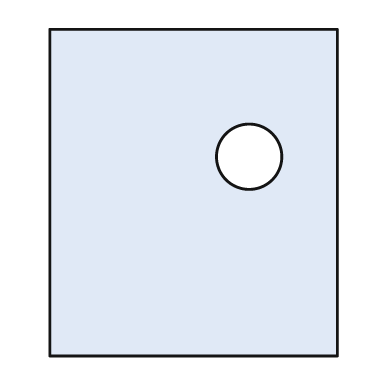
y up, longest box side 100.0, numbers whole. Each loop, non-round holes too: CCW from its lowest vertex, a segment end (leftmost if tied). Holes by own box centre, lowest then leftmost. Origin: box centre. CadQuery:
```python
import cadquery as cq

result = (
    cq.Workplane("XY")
    .moveTo(-44.0, -50.0)
    .lineTo(44.0, -50.0)
    .lineTo(44.0, 50.0)
    .lineTo(-44.0, 50.0)
    .close()
    .moveTo(17.0, 11.0)
    .circle(10.0)
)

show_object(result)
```